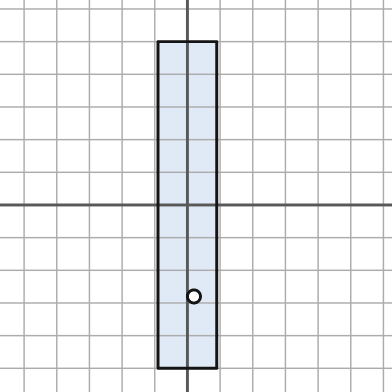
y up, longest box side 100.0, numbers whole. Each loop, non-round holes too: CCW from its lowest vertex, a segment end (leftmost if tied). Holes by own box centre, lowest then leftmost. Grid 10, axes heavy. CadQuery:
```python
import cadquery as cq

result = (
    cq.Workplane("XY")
    .moveTo(-9.0, -50.0)
    .lineTo(9.0, -50.0)
    .lineTo(9.0, 50.0)
    .lineTo(-9.0, 50.0)
    .close()
    .moveTo(2.0, -28.0)
    .circle(2.0)
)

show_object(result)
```